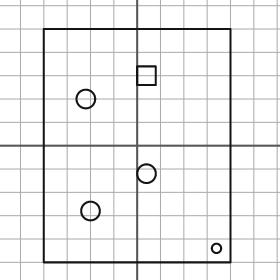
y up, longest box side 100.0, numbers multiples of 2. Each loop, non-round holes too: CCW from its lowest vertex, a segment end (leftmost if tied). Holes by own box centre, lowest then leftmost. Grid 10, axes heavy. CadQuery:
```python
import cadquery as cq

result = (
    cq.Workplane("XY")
    .moveTo(-40.0, -50.0)
    .lineTo(40.0, -50.0)
    .lineTo(40.0, 50.0)
    .lineTo(-40.0, 50.0)
    .close()
    .moveTo(34.0, -44.0)
    .circle(2.0)
    .moveTo(-20.0, -28.0)
    .circle(4.0)
    .moveTo(4.0, -12.0)
    .circle(4.0)
    .moveTo(-22.0, 20.0)
    .circle(4.0)
    .moveTo(0.0, 26.0)
    .lineTo(8.0, 26.0)
    .lineTo(8.0, 34.0)
    .lineTo(0.0, 34.0)
    .close()
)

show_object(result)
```